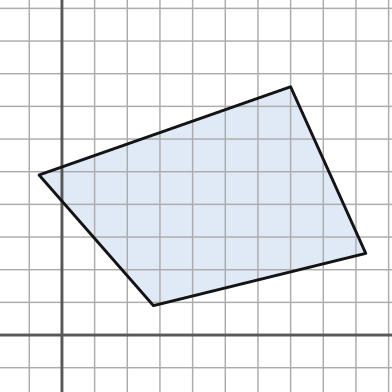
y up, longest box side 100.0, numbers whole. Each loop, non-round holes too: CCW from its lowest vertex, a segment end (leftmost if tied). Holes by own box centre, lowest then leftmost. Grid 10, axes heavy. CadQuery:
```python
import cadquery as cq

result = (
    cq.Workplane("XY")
    .moveTo(28.0, 9.0)
    .lineTo(93.0, 25.0)
    .lineTo(70.0, 76.0)
    .lineTo(-7.0, 49.0)
    .close()
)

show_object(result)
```